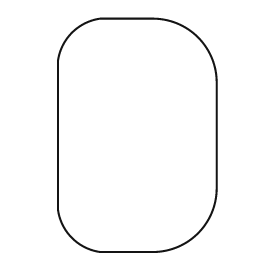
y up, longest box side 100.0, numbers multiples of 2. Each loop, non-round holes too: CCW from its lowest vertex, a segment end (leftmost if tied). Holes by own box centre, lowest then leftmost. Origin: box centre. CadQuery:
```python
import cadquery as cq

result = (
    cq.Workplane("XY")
    .moveTo(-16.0, -50.0)
    .lineTo(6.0, -50.0)
    .threePointArc((26.0, -42.0), (34.0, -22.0))
    .lineTo(34.0, 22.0)
    .threePointArc((26.0, 42.0), (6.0, 50.0))
    .lineTo(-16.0, 50.0)
    .threePointArc((-28.0, 44.0), (-34.0, 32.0))
    .lineTo(-34.0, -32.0)
    .threePointArc((-28.0, -44.0), (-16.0, -50.0))
    .close()
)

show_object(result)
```